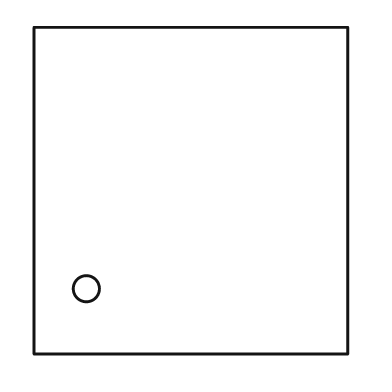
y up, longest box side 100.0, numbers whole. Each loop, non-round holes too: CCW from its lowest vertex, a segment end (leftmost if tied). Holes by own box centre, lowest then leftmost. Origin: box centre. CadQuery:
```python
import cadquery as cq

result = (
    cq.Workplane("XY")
    .moveTo(-48.0, -50.0)
    .lineTo(48.0, -50.0)
    .lineTo(48.0, 50.0)
    .lineTo(-48.0, 50.0)
    .close()
    .moveTo(-32.0, -30.0)
    .circle(4.0)
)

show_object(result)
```